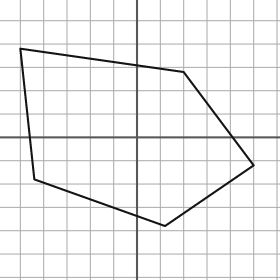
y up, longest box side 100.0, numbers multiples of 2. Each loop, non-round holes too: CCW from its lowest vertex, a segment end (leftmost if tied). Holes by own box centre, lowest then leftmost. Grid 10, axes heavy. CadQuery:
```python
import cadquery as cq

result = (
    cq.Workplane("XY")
    .moveTo(12.0, -38.0)
    .lineTo(50.0, -12.0)
    .lineTo(20.0, 28.0)
    .lineTo(-50.0, 38.0)
    .lineTo(-44.0, -18.0)
    .close()
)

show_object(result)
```